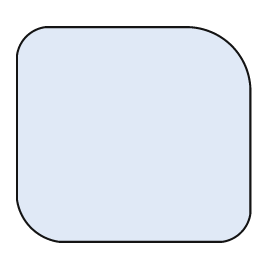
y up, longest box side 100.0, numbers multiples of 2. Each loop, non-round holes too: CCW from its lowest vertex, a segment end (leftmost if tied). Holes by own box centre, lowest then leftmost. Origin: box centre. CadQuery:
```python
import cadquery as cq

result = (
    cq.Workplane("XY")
    .moveTo(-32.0, -46.0)
    .lineTo(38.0, -46.0)
    .threePointArc((46.0, -42.0), (50.0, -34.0))
    .lineTo(50.0, 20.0)
    .threePointArc((42.0, 38.0), (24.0, 46.0))
    .lineTo(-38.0, 46.0)
    .threePointArc((-46.0, 42.0), (-50.0, 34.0))
    .lineTo(-50.0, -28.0)
    .threePointArc((-44.0, -40.0), (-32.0, -46.0))
    .close()
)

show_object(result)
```